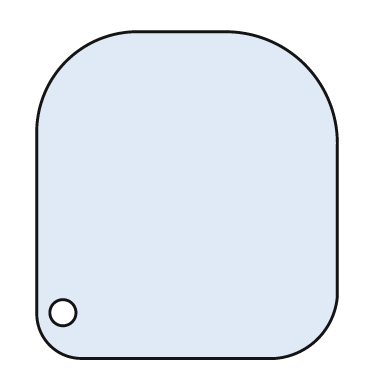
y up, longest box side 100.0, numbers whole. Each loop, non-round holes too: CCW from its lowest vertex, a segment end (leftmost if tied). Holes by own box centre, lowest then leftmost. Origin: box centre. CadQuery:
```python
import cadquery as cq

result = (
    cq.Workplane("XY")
    .moveTo(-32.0, -50.0)
    .lineTo(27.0, -50.0)
    .threePointArc((40.0, -44.0), (46.0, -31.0))
    .lineTo(46.0, 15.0)
    .threePointArc((36.0, 40.0), (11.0, 50.0))
    .lineTo(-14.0, 50.0)
    .threePointArc((-37.0, 41.0), (-46.0, 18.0))
    .lineTo(-46.0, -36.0)
    .threePointArc((-42.0, -46.0), (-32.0, -50.0))
    .close()
    .moveTo(-38.0, -36.0)
    .circle(4.0)
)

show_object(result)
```